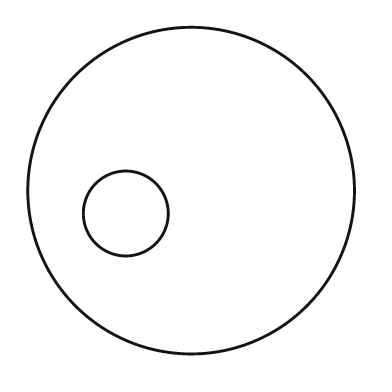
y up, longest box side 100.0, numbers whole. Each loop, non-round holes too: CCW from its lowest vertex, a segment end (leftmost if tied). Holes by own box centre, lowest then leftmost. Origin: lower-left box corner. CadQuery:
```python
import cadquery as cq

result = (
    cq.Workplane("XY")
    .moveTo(50.0, 50.0)
    .circle(50.0)
    .moveTo(30.0, 43.0)
    .circle(13.0)
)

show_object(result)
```